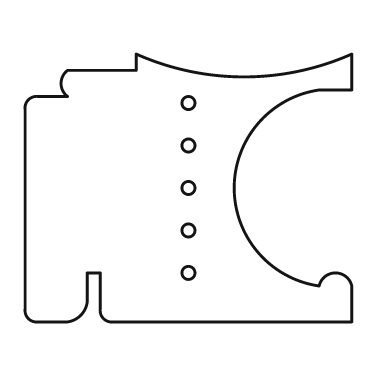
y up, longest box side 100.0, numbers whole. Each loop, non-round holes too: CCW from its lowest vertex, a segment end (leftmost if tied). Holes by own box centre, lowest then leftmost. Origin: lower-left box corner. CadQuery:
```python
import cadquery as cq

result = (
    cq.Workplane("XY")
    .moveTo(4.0, 0.0)
    .lineTo(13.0, 0.0)
    .threePointArc((17.0, 2.0), (19.0, 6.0))
    .lineTo(19.0, 15.0)
    .lineTo(23.0, 15.0)
    .lineTo(23.0, 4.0)
    .threePointArc((24.0, 1.0), (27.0, 0.0))
    .lineTo(100.0, 0.0)
    .lineTo(100.0, 11.0)
    .threePointArc((95.0, 15.0), (90.0, 11.0))
    .threePointArc((64.0, 41.0), (90.0, 71.0))
    .lineTo(100.0, 71.0)
    .lineTo(100.0, 82.0)
    .threePointArc((67.0, 75.0), (34.0, 82.0))
    .lineTo(34.0, 77.0)
    .lineTo(13.0, 77.0)
    .threePointArc((11.0, 73.0), (13.0, 69.0))
    .lineTo(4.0, 69.0)
    .threePointArc((1.0, 68.0), (0.0, 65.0))
    .lineTo(0.0, 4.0)
    .threePointArc((1.0, 1.0), (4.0, 0.0))
    .close()
    .moveTo(50.0, 15.0)
    .circle(2.0)
    .moveTo(50.0, 28.0)
    .circle(2.0)
    .moveTo(50.0, 41.0)
    .circle(2.0)
    .moveTo(50.0, 54.0)
    .circle(2.0)
    .moveTo(50.0, 67.0)
    .circle(2.0)
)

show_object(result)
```